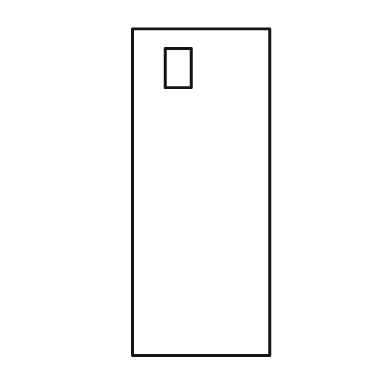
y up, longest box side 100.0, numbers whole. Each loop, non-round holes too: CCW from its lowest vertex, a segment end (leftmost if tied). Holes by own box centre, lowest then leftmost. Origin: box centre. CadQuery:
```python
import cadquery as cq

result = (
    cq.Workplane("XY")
    .moveTo(-21.0, -50.0)
    .lineTo(21.0, -50.0)
    .lineTo(21.0, 50.0)
    .lineTo(-21.0, 50.0)
    .close()
    .moveTo(-11.0, 32.0)
    .lineTo(-3.0, 32.0)
    .lineTo(-3.0, 44.0)
    .lineTo(-11.0, 44.0)
    .close()
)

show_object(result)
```